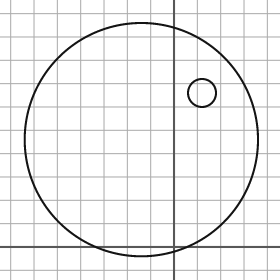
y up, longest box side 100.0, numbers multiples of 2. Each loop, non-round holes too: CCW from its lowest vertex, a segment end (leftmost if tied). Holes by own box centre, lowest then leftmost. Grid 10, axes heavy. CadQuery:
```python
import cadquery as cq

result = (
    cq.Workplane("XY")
    .moveTo(-14.0, 46.0)
    .circle(50.0)
    .moveTo(12.0, 66.0)
    .circle(6.0)
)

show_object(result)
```